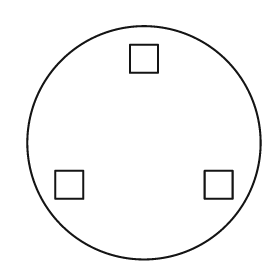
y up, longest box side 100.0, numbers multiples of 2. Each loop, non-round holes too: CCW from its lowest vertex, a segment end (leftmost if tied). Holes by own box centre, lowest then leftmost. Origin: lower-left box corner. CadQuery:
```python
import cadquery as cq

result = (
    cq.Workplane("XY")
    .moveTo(50.0, 50.0)
    .circle(50.0)
    .moveTo(12.0, 26.0)
    .lineTo(24.0, 26.0)
    .lineTo(24.0, 38.0)
    .lineTo(12.0, 38.0)
    .close()
    .moveTo(76.0, 26.0)
    .lineTo(88.0, 26.0)
    .lineTo(88.0, 38.0)
    .lineTo(76.0, 38.0)
    .close()
    .moveTo(44.0, 80.0)
    .lineTo(56.0, 80.0)
    .lineTo(56.0, 92.0)
    .lineTo(44.0, 92.0)
    .close()
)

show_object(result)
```